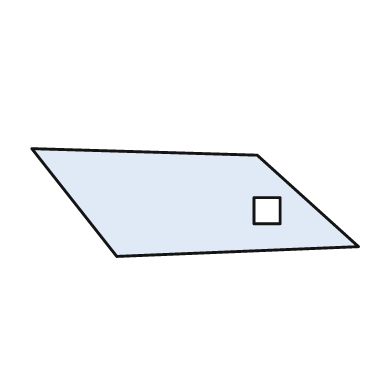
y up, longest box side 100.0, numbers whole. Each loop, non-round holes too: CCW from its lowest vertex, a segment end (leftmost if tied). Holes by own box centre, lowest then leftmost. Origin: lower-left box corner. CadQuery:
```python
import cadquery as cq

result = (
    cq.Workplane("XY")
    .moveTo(26.0, 0.0)
    .lineTo(100.0, 3.0)
    .lineTo(69.0, 31.0)
    .lineTo(0.0, 33.0)
    .close()
    .moveTo(68.0, 10.0)
    .lineTo(76.0, 10.0)
    .lineTo(76.0, 18.0)
    .lineTo(68.0, 18.0)
    .close()
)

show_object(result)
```